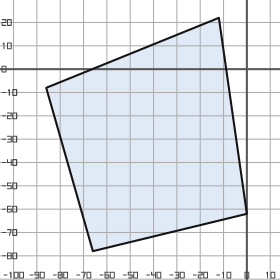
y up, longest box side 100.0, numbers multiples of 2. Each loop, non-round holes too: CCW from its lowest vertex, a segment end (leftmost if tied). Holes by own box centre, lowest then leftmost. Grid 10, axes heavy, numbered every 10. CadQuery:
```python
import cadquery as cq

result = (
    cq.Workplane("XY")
    .moveTo(-66.0, -78.0)
    .lineTo(0.0, -62.0)
    .lineTo(-12.0, 22.0)
    .lineTo(-86.0, -8.0)
    .close()
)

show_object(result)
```